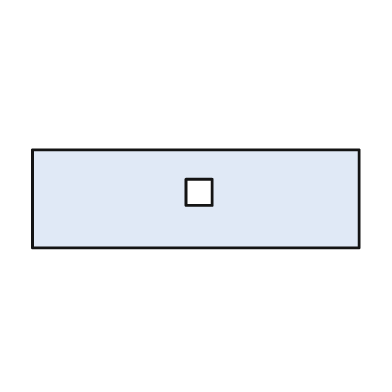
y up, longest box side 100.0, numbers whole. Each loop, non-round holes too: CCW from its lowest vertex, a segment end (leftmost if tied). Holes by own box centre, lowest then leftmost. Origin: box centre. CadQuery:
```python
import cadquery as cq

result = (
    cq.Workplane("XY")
    .moveTo(-50.0, -15.0)
    .lineTo(50.0, -15.0)
    .lineTo(50.0, 15.0)
    .lineTo(-50.0, 15.0)
    .close()
    .moveTo(-3.0, -2.0)
    .lineTo(5.0, -2.0)
    .lineTo(5.0, 6.0)
    .lineTo(-3.0, 6.0)
    .close()
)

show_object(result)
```